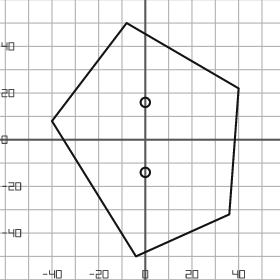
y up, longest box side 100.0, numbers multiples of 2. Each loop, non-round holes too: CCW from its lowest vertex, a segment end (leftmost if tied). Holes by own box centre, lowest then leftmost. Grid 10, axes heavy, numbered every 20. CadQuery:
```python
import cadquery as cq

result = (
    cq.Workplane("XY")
    .moveTo(-4.0, -50.0)
    .lineTo(36.0, -32.0)
    .lineTo(40.0, 22.0)
    .lineTo(-8.0, 50.0)
    .lineTo(-40.0, 8.0)
    .close()
    .moveTo(0.0, -14.0)
    .circle(2.0)
    .moveTo(0.0, 16.0)
    .circle(2.0)
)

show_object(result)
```